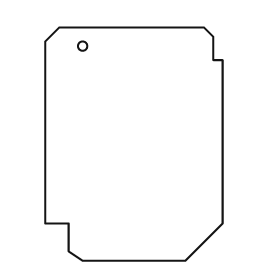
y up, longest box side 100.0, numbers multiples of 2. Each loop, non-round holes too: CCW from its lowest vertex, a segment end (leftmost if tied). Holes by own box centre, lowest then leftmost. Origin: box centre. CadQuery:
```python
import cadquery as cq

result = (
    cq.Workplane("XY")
    .moveTo(-22.0, -50.0)
    .lineTo(22.0, -50.0)
    .lineTo(38.0, -34.0)
    .lineTo(38.0, 36.0)
    .lineTo(34.0, 36.0)
    .lineTo(34.0, 46.0)
    .lineTo(30.0, 50.0)
    .lineTo(-32.0, 50.0)
    .lineTo(-38.0, 44.0)
    .lineTo(-38.0, -34.0)
    .lineTo(-28.0, -34.0)
    .lineTo(-28.0, -46.0)
    .close()
    .moveTo(-22.0, 42.0)
    .circle(2.0)
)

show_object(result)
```